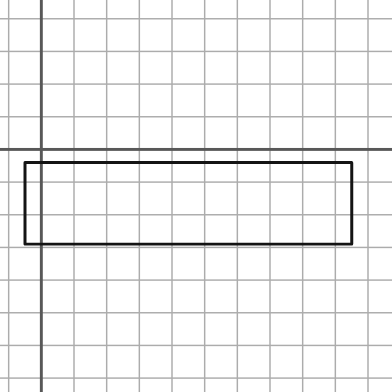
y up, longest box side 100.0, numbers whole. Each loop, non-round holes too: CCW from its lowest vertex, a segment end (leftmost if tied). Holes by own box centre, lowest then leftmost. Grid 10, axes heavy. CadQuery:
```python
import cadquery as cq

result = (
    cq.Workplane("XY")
    .moveTo(-5.0, -29.0)
    .lineTo(95.0, -29.0)
    .lineTo(95.0, -4.0)
    .lineTo(-5.0, -4.0)
    .close()
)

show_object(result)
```